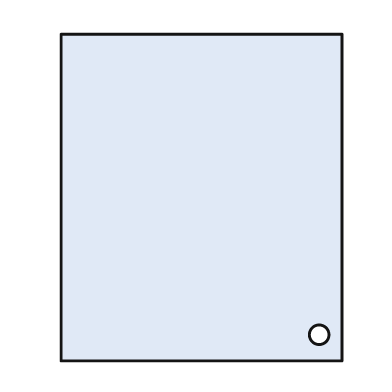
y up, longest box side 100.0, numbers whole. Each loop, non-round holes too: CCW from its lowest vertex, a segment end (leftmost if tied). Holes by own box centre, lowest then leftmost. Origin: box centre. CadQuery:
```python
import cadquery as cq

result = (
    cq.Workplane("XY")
    .moveTo(-43.0, -50.0)
    .lineTo(43.0, -50.0)
    .lineTo(43.0, 50.0)
    .lineTo(-43.0, 50.0)
    .close()
    .moveTo(36.0, -42.0)
    .circle(3.0)
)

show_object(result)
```